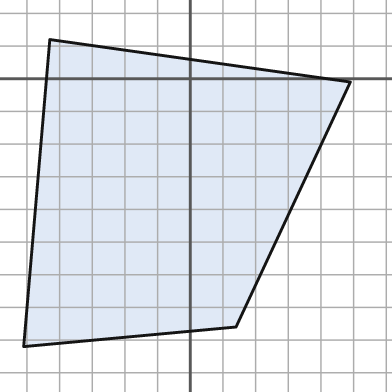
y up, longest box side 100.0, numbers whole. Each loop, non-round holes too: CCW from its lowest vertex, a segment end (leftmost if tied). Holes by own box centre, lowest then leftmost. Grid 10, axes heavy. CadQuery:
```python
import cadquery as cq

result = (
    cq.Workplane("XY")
    .moveTo(-51.0, -82.0)
    .lineTo(14.0, -76.0)
    .lineTo(49.0, -1.0)
    .lineTo(-43.0, 12.0)
    .close()
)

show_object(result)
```